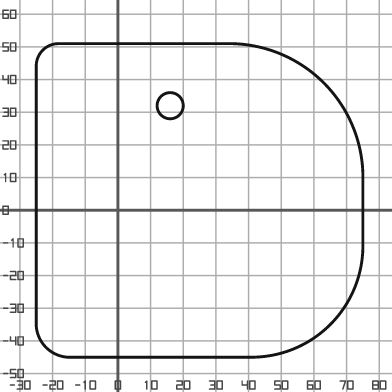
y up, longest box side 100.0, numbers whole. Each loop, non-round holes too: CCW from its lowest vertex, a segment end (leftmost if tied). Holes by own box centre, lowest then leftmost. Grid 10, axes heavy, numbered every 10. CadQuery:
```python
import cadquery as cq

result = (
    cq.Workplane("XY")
    .moveTo(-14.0, -45.0)
    .lineTo(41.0, -45.0)
    .threePointArc((65.0, -35.0), (75.0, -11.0))
    .lineTo(75.0, 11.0)
    .threePointArc((63.0, 39.0), (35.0, 51.0))
    .lineTo(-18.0, 51.0)
    .threePointArc((-23.0, 49.0), (-25.0, 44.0))
    .lineTo(-25.0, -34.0)
    .threePointArc((-22.0, -42.0), (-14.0, -45.0))
    .close()
    .moveTo(16.0, 32.0)
    .circle(4.0)
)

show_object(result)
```